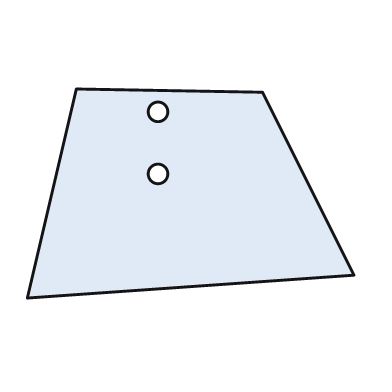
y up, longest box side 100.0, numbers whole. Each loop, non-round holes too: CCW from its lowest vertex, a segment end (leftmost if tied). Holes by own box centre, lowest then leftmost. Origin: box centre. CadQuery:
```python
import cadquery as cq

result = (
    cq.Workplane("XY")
    .moveTo(-50.0, -32.0)
    .lineTo(50.0, -25.0)
    .lineTo(22.0, 31.0)
    .lineTo(-35.0, 32.0)
    .close()
    .moveTo(-10.0, 6.0)
    .circle(3.0)
    .moveTo(-10.0, 25.0)
    .circle(3.0)
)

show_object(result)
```